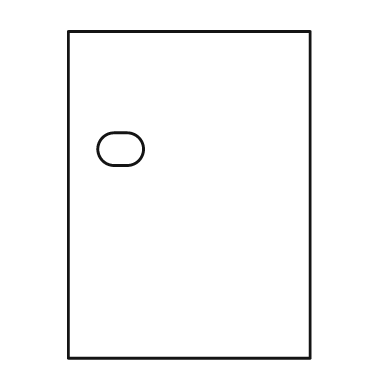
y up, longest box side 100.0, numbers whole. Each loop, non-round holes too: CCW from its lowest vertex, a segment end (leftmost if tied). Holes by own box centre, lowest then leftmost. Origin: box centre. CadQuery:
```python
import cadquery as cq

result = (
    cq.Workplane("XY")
    .moveTo(-37.0, -50.0)
    .lineTo(37.0, -50.0)
    .lineTo(37.0, 50.0)
    .lineTo(-37.0, 50.0)
    .close()
    .moveTo(-23.0, 9.0)
    .lineTo(-19.0, 9.0)
    .threePointArc((-14.0, 14.0), (-19.0, 19.0))
    .lineTo(-23.0, 19.0)
    .threePointArc((-28.0, 14.0), (-23.0, 9.0))
    .close()
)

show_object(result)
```